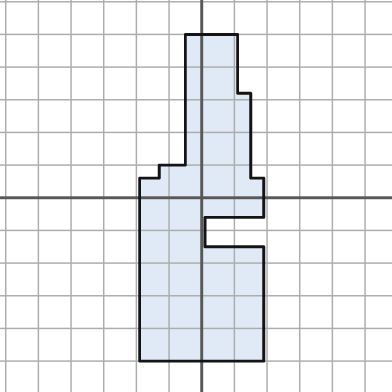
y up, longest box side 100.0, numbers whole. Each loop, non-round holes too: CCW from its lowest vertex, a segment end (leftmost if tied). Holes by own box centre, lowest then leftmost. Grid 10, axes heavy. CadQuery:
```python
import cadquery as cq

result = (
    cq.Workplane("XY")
    .moveTo(-19.0, -50.0)
    .lineTo(19.0, -50.0)
    .lineTo(19.0, -15.0)
    .lineTo(1.0, -15.0)
    .lineTo(1.0, -6.0)
    .lineTo(19.0, -6.0)
    .lineTo(19.0, 6.0)
    .lineTo(15.0, 6.0)
    .lineTo(15.0, 32.0)
    .lineTo(11.0, 32.0)
    .lineTo(11.0, 50.0)
    .lineTo(-5.0, 50.0)
    .lineTo(-5.0, 10.0)
    .lineTo(-13.0, 10.0)
    .lineTo(-13.0, 6.0)
    .lineTo(-19.0, 6.0)
    .close()
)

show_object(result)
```